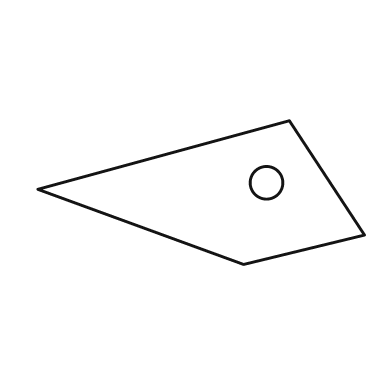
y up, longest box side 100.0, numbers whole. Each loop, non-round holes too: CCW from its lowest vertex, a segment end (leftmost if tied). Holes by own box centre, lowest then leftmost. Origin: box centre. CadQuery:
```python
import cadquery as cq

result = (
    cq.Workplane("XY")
    .moveTo(13.0, -22.0)
    .lineTo(50.0, -13.0)
    .lineTo(27.0, 22.0)
    .lineTo(-50.0, 1.0)
    .close()
    .moveTo(20.0, 3.0)
    .circle(5.0)
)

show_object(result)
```